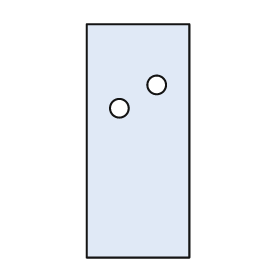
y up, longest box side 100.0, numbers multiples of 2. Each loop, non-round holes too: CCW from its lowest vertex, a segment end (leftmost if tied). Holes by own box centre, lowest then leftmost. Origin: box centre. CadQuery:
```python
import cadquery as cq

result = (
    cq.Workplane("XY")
    .moveTo(-22.0, -50.0)
    .lineTo(22.0, -50.0)
    .lineTo(22.0, 50.0)
    .lineTo(-22.0, 50.0)
    .close()
    .moveTo(-8.0, 14.0)
    .circle(4.0)
    .moveTo(8.0, 24.0)
    .circle(4.0)
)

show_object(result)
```